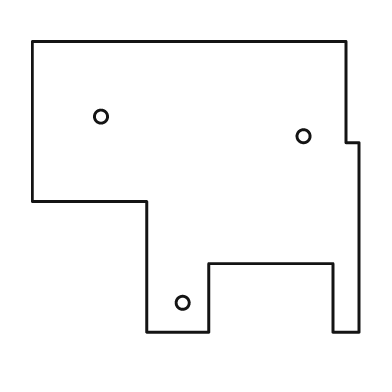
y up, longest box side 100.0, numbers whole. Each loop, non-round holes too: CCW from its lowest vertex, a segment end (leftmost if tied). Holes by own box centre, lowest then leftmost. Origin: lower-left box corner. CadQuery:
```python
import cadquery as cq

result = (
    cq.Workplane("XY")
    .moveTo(35.0, 0.0)
    .lineTo(54.0, 0.0)
    .lineTo(54.0, 21.0)
    .lineTo(92.0, 21.0)
    .lineTo(92.0, 0.0)
    .lineTo(100.0, 0.0)
    .lineTo(100.0, 58.0)
    .lineTo(96.0, 58.0)
    .lineTo(96.0, 89.0)
    .lineTo(0.0, 89.0)
    .lineTo(0.0, 40.0)
    .lineTo(35.0, 40.0)
    .close()
    .moveTo(46.0, 9.0)
    .circle(2.0)
    .moveTo(83.0, 60.0)
    .circle(2.0)
    .moveTo(21.0, 66.0)
    .circle(2.0)
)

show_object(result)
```